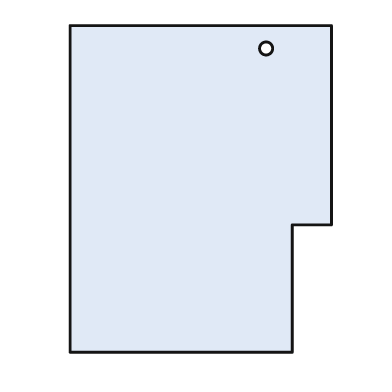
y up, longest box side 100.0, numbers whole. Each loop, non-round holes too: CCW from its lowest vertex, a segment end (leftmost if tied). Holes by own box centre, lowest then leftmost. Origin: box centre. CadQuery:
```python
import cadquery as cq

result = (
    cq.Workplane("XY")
    .moveTo(-40.0, -50.0)
    .lineTo(28.0, -50.0)
    .lineTo(28.0, -11.0)
    .lineTo(40.0, -11.0)
    .lineTo(40.0, 50.0)
    .lineTo(-40.0, 50.0)
    .close()
    .moveTo(20.0, 43.0)
    .circle(2.0)
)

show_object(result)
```